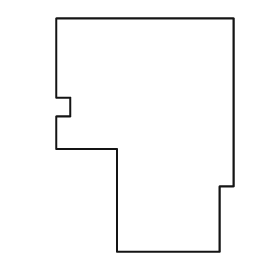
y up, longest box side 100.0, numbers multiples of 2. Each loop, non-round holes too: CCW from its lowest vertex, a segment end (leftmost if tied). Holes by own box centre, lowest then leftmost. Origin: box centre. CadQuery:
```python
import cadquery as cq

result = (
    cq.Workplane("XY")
    .moveTo(-12.0, -50.0)
    .lineTo(32.0, -50.0)
    .lineTo(32.0, -22.0)
    .lineTo(38.0, -22.0)
    .lineTo(38.0, 50.0)
    .lineTo(-38.0, 50.0)
    .lineTo(-38.0, 16.0)
    .lineTo(-32.0, 16.0)
    .lineTo(-32.0, 8.0)
    .lineTo(-38.0, 8.0)
    .lineTo(-38.0, -6.0)
    .lineTo(-12.0, -6.0)
    .close()
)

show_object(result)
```